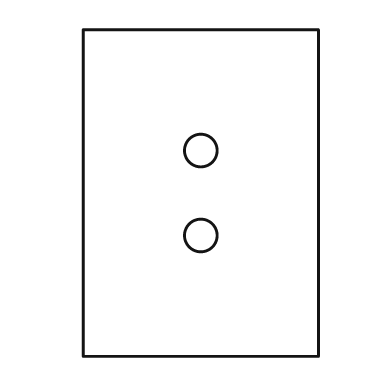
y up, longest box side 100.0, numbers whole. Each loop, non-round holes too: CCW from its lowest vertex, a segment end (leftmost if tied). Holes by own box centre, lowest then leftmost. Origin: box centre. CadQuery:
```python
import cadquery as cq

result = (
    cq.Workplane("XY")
    .moveTo(-36.0, -50.0)
    .lineTo(36.0, -50.0)
    .lineTo(36.0, 50.0)
    .lineTo(-36.0, 50.0)
    .close()
    .moveTo(0.0, -13.0)
    .circle(5.0)
    .moveTo(0.0, 13.0)
    .circle(5.0)
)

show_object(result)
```